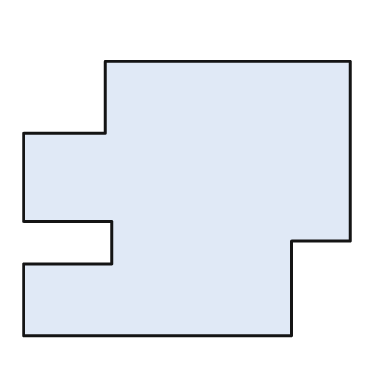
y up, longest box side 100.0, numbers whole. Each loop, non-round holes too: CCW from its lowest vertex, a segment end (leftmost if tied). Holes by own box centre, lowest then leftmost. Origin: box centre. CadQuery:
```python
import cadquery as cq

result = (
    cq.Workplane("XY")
    .moveTo(-50.0, -42.0)
    .lineTo(32.0, -42.0)
    .lineTo(32.0, -13.0)
    .lineTo(50.0, -13.0)
    .lineTo(50.0, 42.0)
    .lineTo(-25.0, 42.0)
    .lineTo(-25.0, 20.0)
    .lineTo(-50.0, 20.0)
    .lineTo(-50.0, -7.0)
    .lineTo(-23.0, -7.0)
    .lineTo(-23.0, -20.0)
    .lineTo(-50.0, -20.0)
    .close()
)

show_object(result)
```